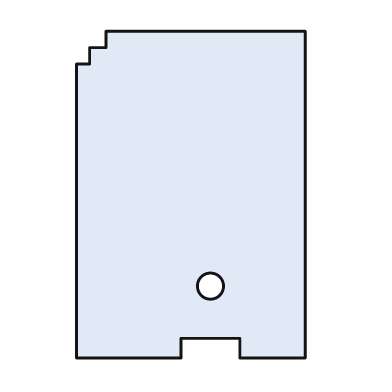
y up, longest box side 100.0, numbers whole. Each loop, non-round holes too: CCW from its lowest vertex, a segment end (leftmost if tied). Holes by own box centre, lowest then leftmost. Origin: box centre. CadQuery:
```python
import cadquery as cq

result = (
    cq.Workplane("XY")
    .moveTo(-35.0, -50.0)
    .lineTo(-3.0, -50.0)
    .lineTo(-3.0, -44.0)
    .lineTo(15.0, -44.0)
    .lineTo(15.0, -50.0)
    .lineTo(35.0, -50.0)
    .lineTo(35.0, 50.0)
    .lineTo(-26.0, 50.0)
    .lineTo(-26.0, 45.0)
    .lineTo(-31.0, 45.0)
    .lineTo(-31.0, 40.0)
    .lineTo(-35.0, 40.0)
    .close()
    .moveTo(6.0, -28.0)
    .circle(4.0)
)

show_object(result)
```